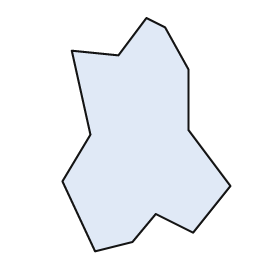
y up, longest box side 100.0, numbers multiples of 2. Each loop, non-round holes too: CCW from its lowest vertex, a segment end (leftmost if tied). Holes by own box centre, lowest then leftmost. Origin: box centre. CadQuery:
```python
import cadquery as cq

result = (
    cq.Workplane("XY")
    .moveTo(-22.0, -50.0)
    .lineTo(-6.0, -46.0)
    .lineTo(4.0, -34.0)
    .lineTo(20.0, -42.0)
    .lineTo(36.0, -22.0)
    .lineTo(18.0, 2.0)
    .lineTo(18.0, 28.0)
    .lineTo(8.0, 46.0)
    .lineTo(0.0, 50.0)
    .lineTo(-12.0, 34.0)
    .lineTo(-32.0, 36.0)
    .lineTo(-24.0, 0.0)
    .lineTo(-36.0, -20.0)
    .close()
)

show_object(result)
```